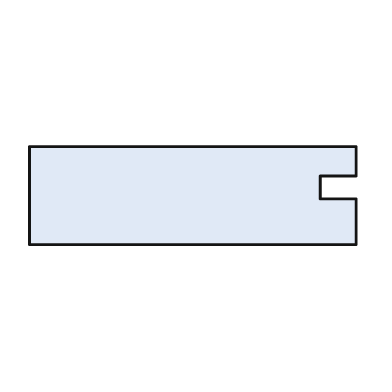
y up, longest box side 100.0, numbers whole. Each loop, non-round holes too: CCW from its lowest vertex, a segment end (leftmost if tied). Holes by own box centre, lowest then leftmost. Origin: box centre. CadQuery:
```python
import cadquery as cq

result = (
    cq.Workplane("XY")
    .moveTo(-50.0, -15.0)
    .lineTo(50.0, -15.0)
    .lineTo(50.0, -1.0)
    .lineTo(39.0, -1.0)
    .lineTo(39.0, 6.0)
    .lineTo(50.0, 6.0)
    .lineTo(50.0, 15.0)
    .lineTo(-50.0, 15.0)
    .close()
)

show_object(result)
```